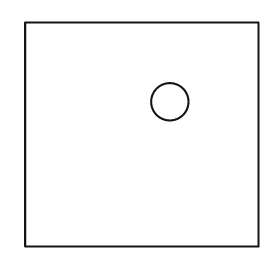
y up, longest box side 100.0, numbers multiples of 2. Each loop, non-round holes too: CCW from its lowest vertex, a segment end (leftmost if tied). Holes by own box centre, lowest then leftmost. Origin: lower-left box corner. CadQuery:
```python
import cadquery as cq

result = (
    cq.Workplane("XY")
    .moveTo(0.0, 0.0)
    .lineTo(100.0, 0.0)
    .lineTo(100.0, 96.0)
    .lineTo(0.0, 96.0)
    .close()
    .moveTo(62.0, 62.0)
    .circle(8.0)
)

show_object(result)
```